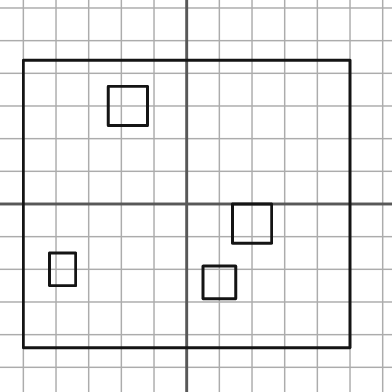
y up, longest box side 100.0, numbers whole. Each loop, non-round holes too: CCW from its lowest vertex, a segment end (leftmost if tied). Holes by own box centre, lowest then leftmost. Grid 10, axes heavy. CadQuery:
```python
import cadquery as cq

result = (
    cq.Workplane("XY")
    .moveTo(-50.0, -44.0)
    .lineTo(50.0, -44.0)
    .lineTo(50.0, 44.0)
    .lineTo(-50.0, 44.0)
    .close()
    .moveTo(5.0, -29.0)
    .lineTo(15.0, -29.0)
    .lineTo(15.0, -19.0)
    .lineTo(5.0, -19.0)
    .close()
    .moveTo(-42.0, -25.0)
    .lineTo(-34.0, -25.0)
    .lineTo(-34.0, -15.0)
    .lineTo(-42.0, -15.0)
    .close()
    .moveTo(14.0, -12.0)
    .lineTo(26.0, -12.0)
    .lineTo(26.0, 0.0)
    .lineTo(14.0, 0.0)
    .close()
    .moveTo(-24.0, 24.0)
    .lineTo(-12.0, 24.0)
    .lineTo(-12.0, 36.0)
    .lineTo(-24.0, 36.0)
    .close()
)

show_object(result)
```